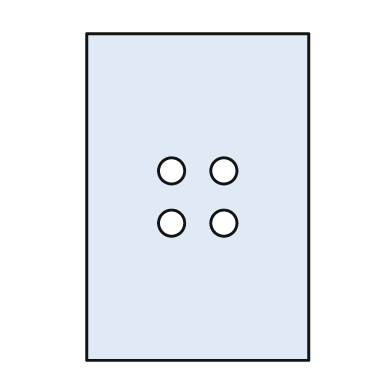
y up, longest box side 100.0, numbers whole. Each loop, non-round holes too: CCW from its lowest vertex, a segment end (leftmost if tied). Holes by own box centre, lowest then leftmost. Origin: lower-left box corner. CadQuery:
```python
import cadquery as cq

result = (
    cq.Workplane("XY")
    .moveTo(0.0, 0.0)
    .lineTo(68.0, 0.0)
    .lineTo(68.0, 100.0)
    .lineTo(0.0, 100.0)
    .close()
    .moveTo(26.0, 42.0)
    .circle(4.0)
    .moveTo(42.0, 42.0)
    .circle(4.0)
    .moveTo(26.0, 58.0)
    .circle(4.0)
    .moveTo(42.0, 58.0)
    .circle(4.0)
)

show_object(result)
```